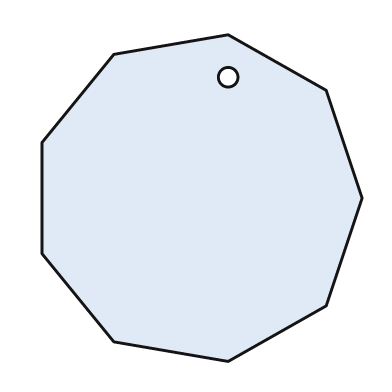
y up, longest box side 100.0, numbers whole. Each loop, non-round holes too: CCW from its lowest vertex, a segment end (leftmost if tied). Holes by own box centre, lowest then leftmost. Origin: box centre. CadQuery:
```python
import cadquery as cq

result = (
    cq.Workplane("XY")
    .moveTo(8.0, -50.0)
    .lineTo(38.0, -33.0)
    .lineTo(49.0, 0.0)
    .lineTo(38.0, 33.0)
    .lineTo(8.0, 50.0)
    .lineTo(-27.0, 44.0)
    .lineTo(-49.0, 17.0)
    .lineTo(-49.0, -17.0)
    .lineTo(-27.0, -44.0)
    .close()
    .moveTo(8.0, 37.0)
    .circle(3.0)
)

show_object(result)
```